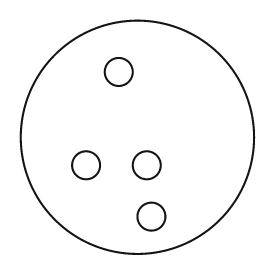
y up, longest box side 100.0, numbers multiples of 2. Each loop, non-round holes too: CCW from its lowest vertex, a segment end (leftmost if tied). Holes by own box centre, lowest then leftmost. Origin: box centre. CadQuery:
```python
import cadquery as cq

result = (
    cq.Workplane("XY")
    .moveTo(0.0, 0.0)
    .circle(50.0)
    .moveTo(6.0, -34.0)
    .circle(6.0)
    .moveTo(-22.0, -12.0)
    .circle(6.0)
    .moveTo(4.0, -12.0)
    .circle(6.0)
    .moveTo(-8.0, 28.0)
    .circle(6.0)
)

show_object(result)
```